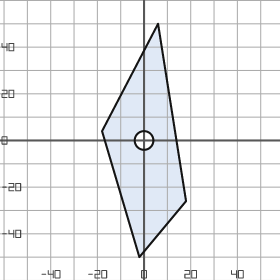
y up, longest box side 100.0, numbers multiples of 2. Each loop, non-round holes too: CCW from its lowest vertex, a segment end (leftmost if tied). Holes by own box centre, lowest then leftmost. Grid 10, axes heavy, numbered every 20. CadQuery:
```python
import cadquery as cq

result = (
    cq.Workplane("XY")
    .moveTo(-2.0, -50.0)
    .lineTo(18.0, -26.0)
    .lineTo(6.0, 50.0)
    .lineTo(-18.0, 4.0)
    .close()
    .moveTo(0.0, 0.0)
    .circle(4.0)
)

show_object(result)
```